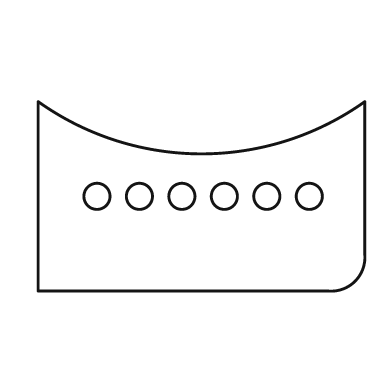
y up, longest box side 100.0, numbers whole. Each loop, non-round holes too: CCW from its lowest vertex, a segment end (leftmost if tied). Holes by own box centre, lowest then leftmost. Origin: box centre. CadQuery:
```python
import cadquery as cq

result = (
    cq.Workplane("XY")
    .moveTo(-50.0, -29.0)
    .lineTo(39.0, -29.0)
    .threePointArc((47.0, -26.0), (50.0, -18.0))
    .lineTo(50.0, 29.0)
    .threePointArc((0.0, 13.0), (-50.0, 29.0))
    .close()
    .moveTo(-32.0, 0.0)
    .circle(4.0)
    .moveTo(-19.0, 0.0)
    .circle(4.0)
    .moveTo(-6.0, 0.0)
    .circle(4.0)
    .moveTo(7.0, 0.0)
    .circle(4.0)
    .moveTo(20.0, 0.0)
    .circle(4.0)
    .moveTo(33.0, 0.0)
    .circle(4.0)
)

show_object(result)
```